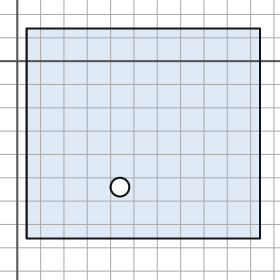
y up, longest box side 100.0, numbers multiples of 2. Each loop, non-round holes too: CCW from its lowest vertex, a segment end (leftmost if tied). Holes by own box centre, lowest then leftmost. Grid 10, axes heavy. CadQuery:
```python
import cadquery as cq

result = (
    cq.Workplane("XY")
    .moveTo(4.0, -76.0)
    .lineTo(104.0, -76.0)
    .lineTo(104.0, 14.0)
    .lineTo(4.0, 14.0)
    .close()
    .moveTo(44.0, -54.0)
    .circle(4.0)
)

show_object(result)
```